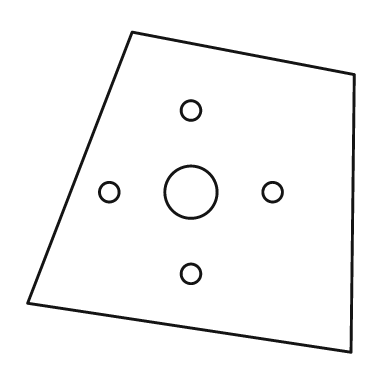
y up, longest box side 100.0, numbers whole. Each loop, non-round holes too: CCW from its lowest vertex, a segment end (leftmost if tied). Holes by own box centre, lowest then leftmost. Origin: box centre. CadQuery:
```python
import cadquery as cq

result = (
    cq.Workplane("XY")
    .moveTo(49.0, -49.0)
    .lineTo(50.0, 36.0)
    .lineTo(-18.0, 49.0)
    .lineTo(-50.0, -34.0)
    .close()
    .moveTo(0.0, -25.0)
    .circle(3.0)
    .moveTo(-25.0, 0.0)
    .circle(3.0)
    .moveTo(0.0, 0.0)
    .circle(8.0)
    .moveTo(25.0, 0.0)
    .circle(3.0)
    .moveTo(0.0, 25.0)
    .circle(3.0)
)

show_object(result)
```